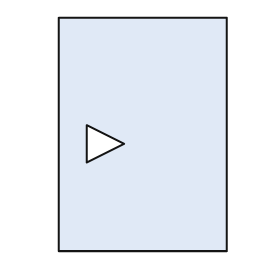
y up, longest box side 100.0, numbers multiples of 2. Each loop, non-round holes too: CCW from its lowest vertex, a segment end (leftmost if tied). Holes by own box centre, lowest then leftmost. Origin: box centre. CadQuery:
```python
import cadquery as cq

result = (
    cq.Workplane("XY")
    .moveTo(-36.0, -50.0)
    .lineTo(36.0, -50.0)
    .lineTo(36.0, 50.0)
    .lineTo(-36.0, 50.0)
    .close()
    .moveTo(-24.0, -12.0)
    .lineTo(-8.0, -4.0)
    .lineTo(-24.0, 4.0)
    .close()
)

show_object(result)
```